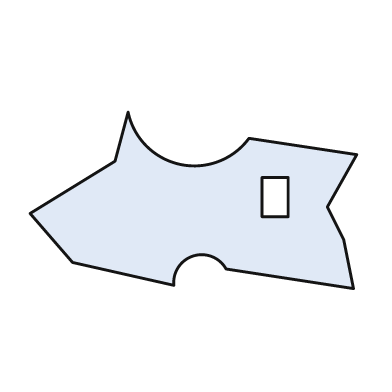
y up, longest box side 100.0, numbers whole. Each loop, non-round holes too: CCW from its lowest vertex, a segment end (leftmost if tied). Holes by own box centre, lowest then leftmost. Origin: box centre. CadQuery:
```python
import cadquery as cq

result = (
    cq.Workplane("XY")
    .moveTo(49.0, -27.0)
    .lineTo(46.0, -12.0)
    .lineTo(41.0, -2.0)
    .lineTo(50.0, 14.0)
    .lineTo(17.0, 19.0)
    .threePointArc((-4.0, 11.0), (-20.0, 27.0))
    .lineTo(-24.0, 12.0)
    .lineTo(-50.0, -4.0)
    .lineTo(-37.0, -19.0)
    .lineTo(-6.0, -26.0)
    .threePointArc((0.0, -17.0), (10.0, -21.0))
    .close()
    .moveTo(21.0, -5.0)
    .lineTo(29.0, -5.0)
    .lineTo(29.0, 7.0)
    .lineTo(21.0, 7.0)
    .close()
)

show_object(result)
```